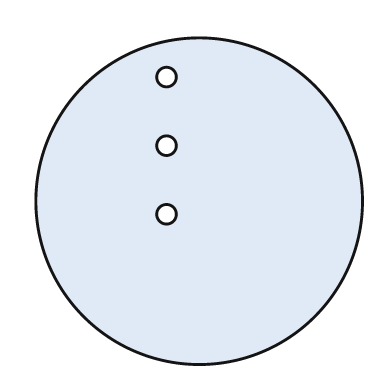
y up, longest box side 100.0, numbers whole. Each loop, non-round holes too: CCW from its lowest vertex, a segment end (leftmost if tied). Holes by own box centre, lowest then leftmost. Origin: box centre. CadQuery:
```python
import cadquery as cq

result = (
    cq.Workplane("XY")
    .moveTo(0.0, 0.0)
    .circle(50.0)
    .moveTo(-10.0, -4.0)
    .circle(3.0)
    .moveTo(-10.0, 17.0)
    .circle(3.0)
    .moveTo(-10.0, 38.0)
    .circle(3.0)
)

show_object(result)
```